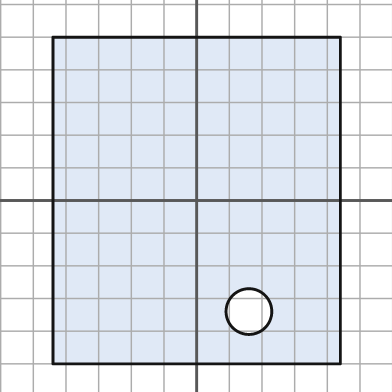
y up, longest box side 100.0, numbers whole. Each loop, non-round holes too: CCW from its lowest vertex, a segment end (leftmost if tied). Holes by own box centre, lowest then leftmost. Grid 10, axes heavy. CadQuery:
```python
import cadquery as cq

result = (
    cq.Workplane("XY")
    .moveTo(-44.0, -50.0)
    .lineTo(44.0, -50.0)
    .lineTo(44.0, 50.0)
    .lineTo(-44.0, 50.0)
    .close()
    .moveTo(16.0, -34.0)
    .circle(7.0)
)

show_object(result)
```